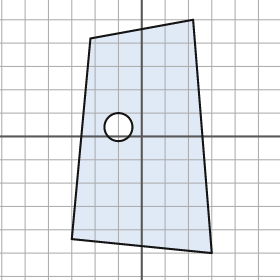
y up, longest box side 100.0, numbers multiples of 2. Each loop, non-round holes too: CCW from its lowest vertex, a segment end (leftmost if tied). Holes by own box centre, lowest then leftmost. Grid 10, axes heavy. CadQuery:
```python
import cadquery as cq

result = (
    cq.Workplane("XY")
    .moveTo(30.0, -50.0)
    .lineTo(22.0, 50.0)
    .lineTo(-22.0, 42.0)
    .lineTo(-30.0, -44.0)
    .close()
    .moveTo(-10.0, 4.0)
    .circle(6.0)
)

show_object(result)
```